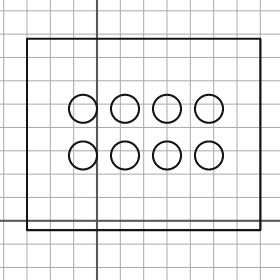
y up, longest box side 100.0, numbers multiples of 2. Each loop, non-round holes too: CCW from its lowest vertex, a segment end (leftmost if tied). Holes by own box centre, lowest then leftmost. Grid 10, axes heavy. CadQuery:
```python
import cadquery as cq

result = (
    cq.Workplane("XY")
    .moveTo(-30.0, -4.0)
    .lineTo(70.0, -4.0)
    .lineTo(70.0, 78.0)
    .lineTo(-30.0, 78.0)
    .close()
    .moveTo(-6.0, 28.0)
    .circle(6.0)
    .moveTo(12.0, 28.0)
    .circle(6.0)
    .moveTo(30.0, 28.0)
    .circle(6.0)
    .moveTo(48.0, 28.0)
    .circle(6.0)
    .moveTo(-6.0, 48.0)
    .circle(6.0)
    .moveTo(12.0, 48.0)
    .circle(6.0)
    .moveTo(30.0, 48.0)
    .circle(6.0)
    .moveTo(48.0, 48.0)
    .circle(6.0)
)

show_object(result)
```